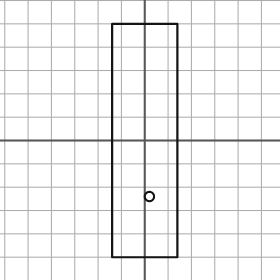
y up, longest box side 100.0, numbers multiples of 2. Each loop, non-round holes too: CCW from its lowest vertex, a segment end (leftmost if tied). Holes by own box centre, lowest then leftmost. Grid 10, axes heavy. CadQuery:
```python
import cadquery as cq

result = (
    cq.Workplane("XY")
    .moveTo(-14.0, -50.0)
    .lineTo(14.0, -50.0)
    .lineTo(14.0, 50.0)
    .lineTo(-14.0, 50.0)
    .close()
    .moveTo(2.0, -24.0)
    .circle(2.0)
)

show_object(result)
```